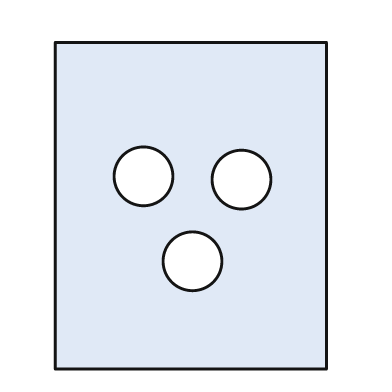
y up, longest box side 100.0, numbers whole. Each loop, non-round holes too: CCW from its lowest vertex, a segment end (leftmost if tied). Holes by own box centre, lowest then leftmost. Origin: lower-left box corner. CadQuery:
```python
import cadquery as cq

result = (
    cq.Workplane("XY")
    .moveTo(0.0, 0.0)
    .lineTo(83.0, 0.0)
    .lineTo(83.0, 100.0)
    .lineTo(0.0, 100.0)
    .close()
    .moveTo(42.0, 33.0)
    .circle(9.0)
    .moveTo(57.0, 58.0)
    .circle(9.0)
    .moveTo(27.0, 59.0)
    .circle(9.0)
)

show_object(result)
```